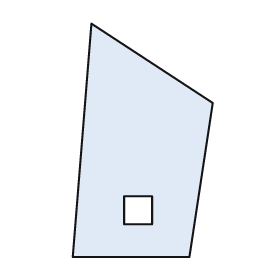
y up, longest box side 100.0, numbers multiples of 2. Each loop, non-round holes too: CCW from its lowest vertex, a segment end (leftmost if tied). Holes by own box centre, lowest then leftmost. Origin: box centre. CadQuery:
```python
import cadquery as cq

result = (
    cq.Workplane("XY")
    .moveTo(-30.0, -50.0)
    .lineTo(20.0, -50.0)
    .lineTo(30.0, 16.0)
    .lineTo(-22.0, 50.0)
    .close()
    .moveTo(-8.0, -36.0)
    .lineTo(4.0, -36.0)
    .lineTo(4.0, -24.0)
    .lineTo(-8.0, -24.0)
    .close()
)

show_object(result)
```